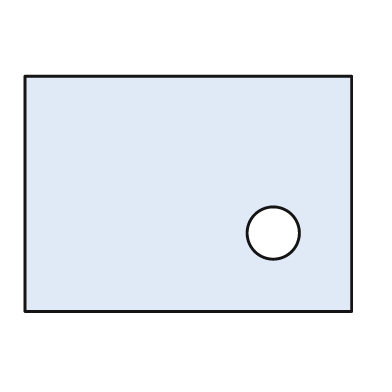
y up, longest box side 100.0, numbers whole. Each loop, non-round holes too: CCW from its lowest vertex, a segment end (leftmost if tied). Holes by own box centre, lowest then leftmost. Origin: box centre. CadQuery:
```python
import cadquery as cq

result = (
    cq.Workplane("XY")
    .moveTo(-50.0, -36.0)
    .lineTo(50.0, -36.0)
    .lineTo(50.0, 36.0)
    .lineTo(-50.0, 36.0)
    .close()
    .moveTo(26.0, -12.0)
    .circle(8.0)
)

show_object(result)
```